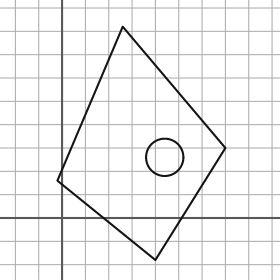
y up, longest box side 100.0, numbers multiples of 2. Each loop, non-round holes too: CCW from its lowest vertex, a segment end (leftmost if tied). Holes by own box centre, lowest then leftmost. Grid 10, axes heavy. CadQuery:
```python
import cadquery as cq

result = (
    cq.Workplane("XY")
    .moveTo(40.0, -18.0)
    .lineTo(70.0, 30.0)
    .lineTo(26.0, 82.0)
    .lineTo(-2.0, 16.0)
    .close()
    .moveTo(44.0, 26.0)
    .circle(8.0)
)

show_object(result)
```